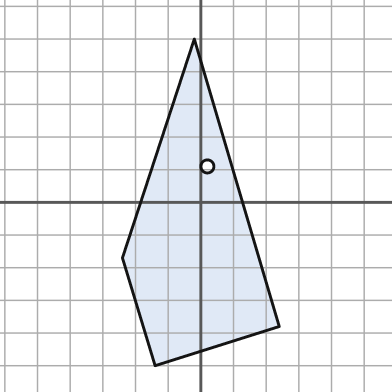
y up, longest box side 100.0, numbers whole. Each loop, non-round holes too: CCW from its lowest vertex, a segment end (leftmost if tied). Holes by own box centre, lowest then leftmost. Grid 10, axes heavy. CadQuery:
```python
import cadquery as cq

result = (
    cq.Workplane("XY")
    .moveTo(-14.0, -50.0)
    .lineTo(24.0, -38.0)
    .lineTo(-2.0, 50.0)
    .lineTo(-24.0, -17.0)
    .close()
    .moveTo(2.0, 11.0)
    .circle(2.0)
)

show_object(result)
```